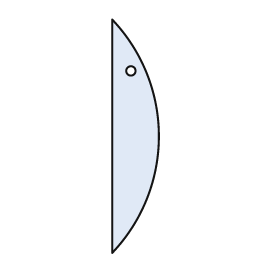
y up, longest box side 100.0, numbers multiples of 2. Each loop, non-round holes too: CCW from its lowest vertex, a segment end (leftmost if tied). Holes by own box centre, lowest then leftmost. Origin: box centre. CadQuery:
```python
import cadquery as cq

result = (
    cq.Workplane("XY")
    .moveTo(-10.0, -50.0)
    .threePointArc((10.0, 0.0), (-10.0, 50.0))
    .close()
    .moveTo(-2.0, 28.0)
    .circle(2.0)
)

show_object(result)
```